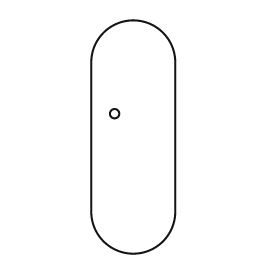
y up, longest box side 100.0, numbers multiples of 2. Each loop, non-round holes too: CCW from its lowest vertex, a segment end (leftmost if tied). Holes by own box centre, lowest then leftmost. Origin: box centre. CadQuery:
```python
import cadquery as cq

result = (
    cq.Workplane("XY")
    .moveTo(-18.0, -32.0)
    .threePointArc((0.0, -50.0), (18.0, -32.0))
    .lineTo(18.0, 32.0)
    .threePointArc((0.0, 50.0), (-18.0, 32.0))
    .close()
    .moveTo(-8.0, 10.0)
    .circle(2.0)
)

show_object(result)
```